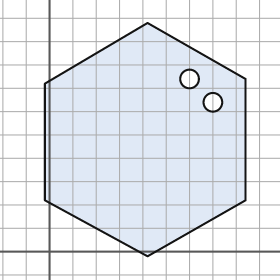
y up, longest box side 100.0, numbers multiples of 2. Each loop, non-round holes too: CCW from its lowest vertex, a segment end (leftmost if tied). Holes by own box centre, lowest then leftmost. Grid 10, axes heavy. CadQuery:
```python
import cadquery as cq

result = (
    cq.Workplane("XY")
    .moveTo(42.0, -2.0)
    .lineTo(84.0, 22.0)
    .lineTo(84.0, 74.0)
    .lineTo(42.0, 98.0)
    .lineTo(-2.0, 72.0)
    .lineTo(-2.0, 22.0)
    .close()
    .moveTo(70.0, 64.0)
    .circle(4.0)
    .moveTo(60.0, 74.0)
    .circle(4.0)
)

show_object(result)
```